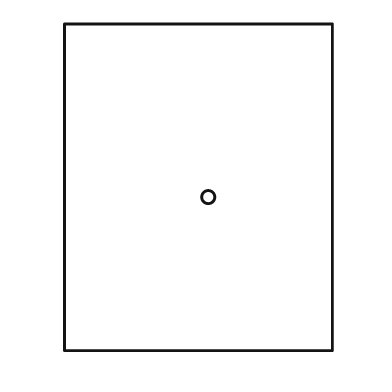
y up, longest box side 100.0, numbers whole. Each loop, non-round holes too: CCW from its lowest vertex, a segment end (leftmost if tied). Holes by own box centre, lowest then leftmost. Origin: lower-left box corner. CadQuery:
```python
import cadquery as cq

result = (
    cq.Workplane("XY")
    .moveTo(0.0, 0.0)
    .lineTo(82.0, 0.0)
    .lineTo(82.0, 100.0)
    .lineTo(0.0, 100.0)
    .close()
    .moveTo(44.0, 47.0)
    .circle(2.0)
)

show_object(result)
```